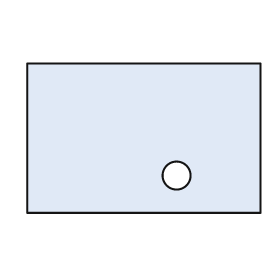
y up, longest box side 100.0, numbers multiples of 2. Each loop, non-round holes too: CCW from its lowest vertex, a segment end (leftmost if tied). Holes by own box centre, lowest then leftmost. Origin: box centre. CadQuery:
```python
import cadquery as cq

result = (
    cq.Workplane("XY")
    .moveTo(-50.0, -32.0)
    .lineTo(50.0, -32.0)
    .lineTo(50.0, 32.0)
    .lineTo(-50.0, 32.0)
    .close()
    .moveTo(14.0, -16.0)
    .circle(6.0)
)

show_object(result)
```